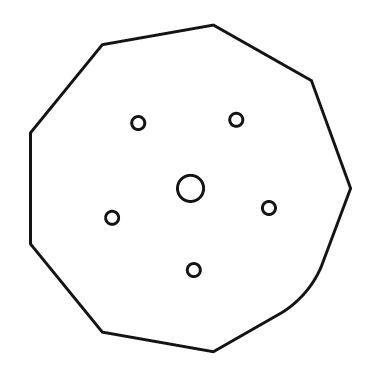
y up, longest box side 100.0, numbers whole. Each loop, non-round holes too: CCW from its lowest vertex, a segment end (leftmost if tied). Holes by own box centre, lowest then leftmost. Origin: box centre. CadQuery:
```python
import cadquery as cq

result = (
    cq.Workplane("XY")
    .moveTo(7.0, -50.0)
    .lineTo(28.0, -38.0)
    .threePointArc((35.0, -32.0), (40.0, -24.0))
    .lineTo(49.0, 0.0)
    .lineTo(37.0, 33.0)
    .lineTo(7.0, 50.0)
    .lineTo(-27.0, 44.0)
    .lineTo(-49.0, 17.0)
    .lineTo(-49.0, -17.0)
    .lineTo(-27.0, -44.0)
    .close()
    .moveTo(1.0, -25.0)
    .circle(2.0)
    .moveTo(-24.0, -9.0)
    .circle(2.0)
    .moveTo(24.0, -6.0)
    .circle(2.0)
    .moveTo(0.0, 0.0)
    .circle(4.0)
    .moveTo(-16.0, 20.0)
    .circle(2.0)
    .moveTo(14.0, 21.0)
    .circle(2.0)
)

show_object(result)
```